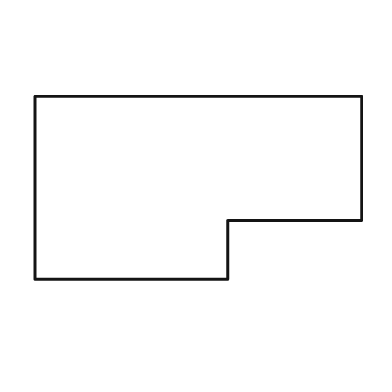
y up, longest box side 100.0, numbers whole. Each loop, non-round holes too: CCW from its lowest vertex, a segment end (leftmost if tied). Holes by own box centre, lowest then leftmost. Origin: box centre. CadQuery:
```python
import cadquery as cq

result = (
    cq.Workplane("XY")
    .moveTo(-50.0, -28.0)
    .lineTo(9.0, -28.0)
    .lineTo(9.0, -10.0)
    .lineTo(50.0, -10.0)
    .lineTo(50.0, 28.0)
    .lineTo(-50.0, 28.0)
    .close()
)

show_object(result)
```